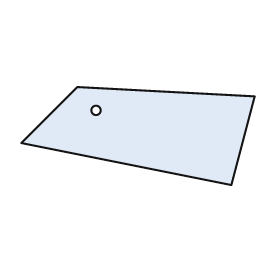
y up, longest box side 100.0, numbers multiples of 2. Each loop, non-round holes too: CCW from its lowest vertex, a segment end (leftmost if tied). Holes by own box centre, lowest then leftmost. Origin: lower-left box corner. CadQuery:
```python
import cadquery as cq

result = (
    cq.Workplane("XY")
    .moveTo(90.0, 0.0)
    .lineTo(100.0, 38.0)
    .lineTo(24.0, 42.0)
    .lineTo(0.0, 18.0)
    .close()
    .moveTo(32.0, 32.0)
    .circle(2.0)
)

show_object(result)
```